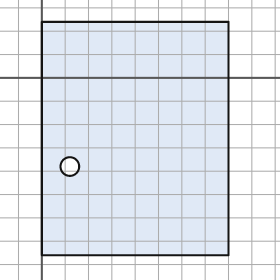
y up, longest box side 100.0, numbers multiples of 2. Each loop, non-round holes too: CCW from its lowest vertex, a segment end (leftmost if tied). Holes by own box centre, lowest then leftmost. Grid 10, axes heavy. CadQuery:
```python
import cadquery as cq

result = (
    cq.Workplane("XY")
    .moveTo(0.0, -76.0)
    .lineTo(80.0, -76.0)
    .lineTo(80.0, 24.0)
    .lineTo(0.0, 24.0)
    .close()
    .moveTo(12.0, -38.0)
    .circle(4.0)
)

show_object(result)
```